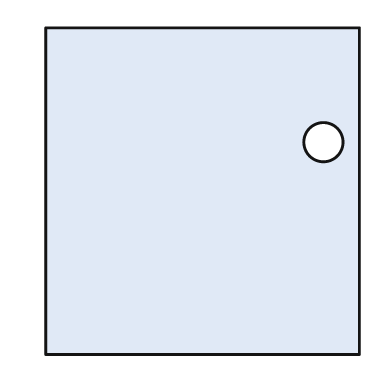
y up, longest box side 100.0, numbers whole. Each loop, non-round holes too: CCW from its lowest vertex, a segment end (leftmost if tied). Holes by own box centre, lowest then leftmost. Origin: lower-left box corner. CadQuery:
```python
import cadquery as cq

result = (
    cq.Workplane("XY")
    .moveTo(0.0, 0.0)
    .lineTo(96.0, 0.0)
    .lineTo(96.0, 100.0)
    .lineTo(0.0, 100.0)
    .close()
    .moveTo(85.0, 65.0)
    .circle(6.0)
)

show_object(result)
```